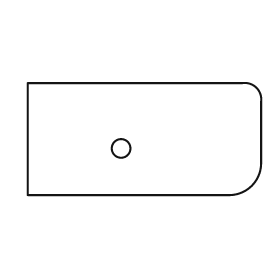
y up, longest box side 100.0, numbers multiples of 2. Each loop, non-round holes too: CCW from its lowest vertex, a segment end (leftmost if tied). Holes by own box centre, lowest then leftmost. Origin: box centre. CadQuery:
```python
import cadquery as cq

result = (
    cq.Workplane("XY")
    .moveTo(-50.0, -24.0)
    .lineTo(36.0, -24.0)
    .threePointArc((46.0, -20.0), (50.0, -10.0))
    .lineTo(50.0, 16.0)
    .threePointArc((48.0, 22.0), (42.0, 24.0))
    .lineTo(-50.0, 24.0)
    .close()
    .moveTo(-10.0, -4.0)
    .circle(4.0)
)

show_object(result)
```